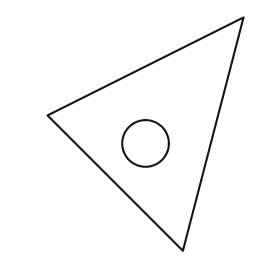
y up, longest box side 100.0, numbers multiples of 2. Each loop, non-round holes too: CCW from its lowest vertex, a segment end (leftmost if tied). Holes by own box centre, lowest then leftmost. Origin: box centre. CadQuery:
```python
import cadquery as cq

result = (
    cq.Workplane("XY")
    .moveTo(16.0, -50.0)
    .lineTo(42.0, 50.0)
    .lineTo(-42.0, 8.0)
    .close()
    .moveTo(0.0, -4.0)
    .circle(10.0)
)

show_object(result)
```